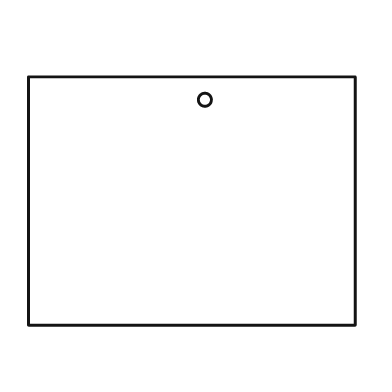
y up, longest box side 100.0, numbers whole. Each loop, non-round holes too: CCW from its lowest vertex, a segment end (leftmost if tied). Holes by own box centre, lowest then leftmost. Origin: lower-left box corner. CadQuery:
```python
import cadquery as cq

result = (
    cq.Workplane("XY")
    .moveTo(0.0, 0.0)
    .lineTo(100.0, 0.0)
    .lineTo(100.0, 76.0)
    .lineTo(0.0, 76.0)
    .close()
    .moveTo(54.0, 69.0)
    .circle(2.0)
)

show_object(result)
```